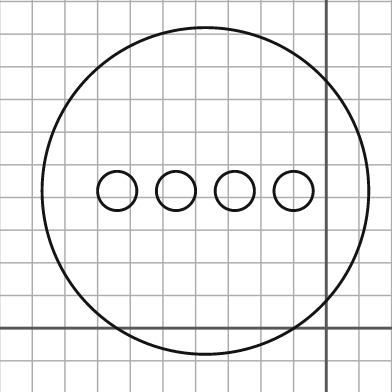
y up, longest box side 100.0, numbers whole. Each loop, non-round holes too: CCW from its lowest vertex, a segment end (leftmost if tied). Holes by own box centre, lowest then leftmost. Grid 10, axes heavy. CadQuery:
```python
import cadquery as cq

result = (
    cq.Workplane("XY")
    .moveTo(-37.0, 42.0)
    .circle(50.0)
    .moveTo(-64.0, 42.0)
    .circle(6.0)
    .moveTo(-46.0, 42.0)
    .circle(6.0)
    .moveTo(-28.0, 42.0)
    .circle(6.0)
    .moveTo(-10.0, 42.0)
    .circle(6.0)
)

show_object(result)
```